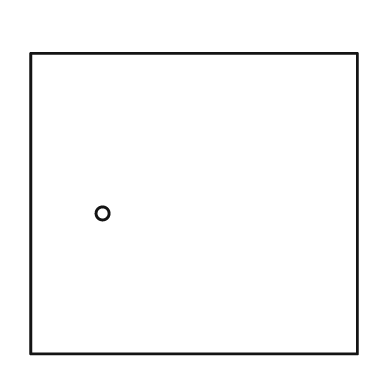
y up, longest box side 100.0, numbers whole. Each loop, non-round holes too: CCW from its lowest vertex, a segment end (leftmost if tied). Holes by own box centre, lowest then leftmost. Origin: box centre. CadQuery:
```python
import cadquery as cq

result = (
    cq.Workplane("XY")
    .moveTo(-50.0, -46.0)
    .lineTo(50.0, -46.0)
    .lineTo(50.0, 46.0)
    .lineTo(-50.0, 46.0)
    .close()
    .moveTo(-28.0, -3.0)
    .circle(2.0)
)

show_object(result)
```